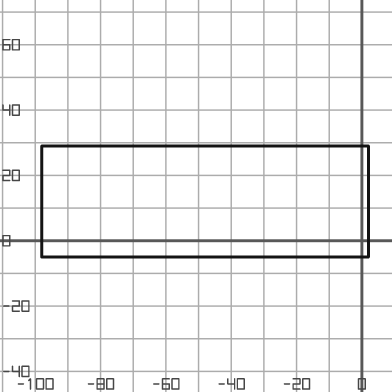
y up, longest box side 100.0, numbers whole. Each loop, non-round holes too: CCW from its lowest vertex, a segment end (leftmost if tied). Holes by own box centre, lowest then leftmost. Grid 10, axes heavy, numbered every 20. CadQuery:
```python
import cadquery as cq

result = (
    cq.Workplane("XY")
    .moveTo(-98.0, -5.0)
    .lineTo(2.0, -5.0)
    .lineTo(2.0, 29.0)
    .lineTo(-98.0, 29.0)
    .close()
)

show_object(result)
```